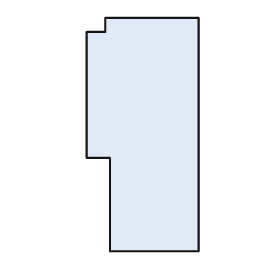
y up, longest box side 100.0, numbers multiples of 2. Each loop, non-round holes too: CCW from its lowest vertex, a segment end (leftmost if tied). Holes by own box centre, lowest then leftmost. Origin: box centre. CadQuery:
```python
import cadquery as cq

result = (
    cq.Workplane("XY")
    .moveTo(-14.0, -50.0)
    .lineTo(24.0, -50.0)
    .lineTo(24.0, 50.0)
    .lineTo(-16.0, 50.0)
    .lineTo(-16.0, 44.0)
    .lineTo(-24.0, 44.0)
    .lineTo(-24.0, -10.0)
    .lineTo(-14.0, -10.0)
    .close()
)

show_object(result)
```